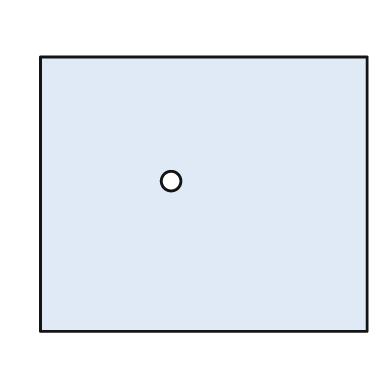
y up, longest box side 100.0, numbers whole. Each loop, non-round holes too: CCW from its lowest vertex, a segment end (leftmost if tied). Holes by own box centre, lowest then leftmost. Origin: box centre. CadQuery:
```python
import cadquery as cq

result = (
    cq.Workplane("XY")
    .moveTo(-50.0, -42.0)
    .lineTo(50.0, -42.0)
    .lineTo(50.0, 42.0)
    .lineTo(-50.0, 42.0)
    .close()
    .moveTo(-10.0, 4.0)
    .circle(3.0)
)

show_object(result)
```